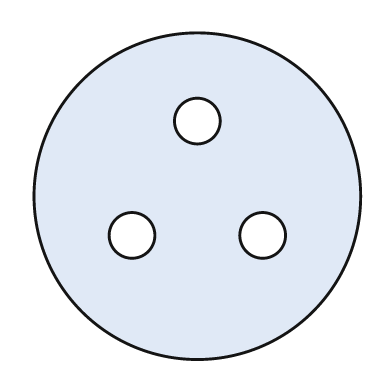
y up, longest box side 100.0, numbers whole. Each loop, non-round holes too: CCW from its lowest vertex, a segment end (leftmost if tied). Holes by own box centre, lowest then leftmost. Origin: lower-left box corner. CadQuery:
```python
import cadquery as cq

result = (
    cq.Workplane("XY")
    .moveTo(50.0, 50.0)
    .circle(50.0)
    .moveTo(30.0, 38.0)
    .circle(7.0)
    .moveTo(70.0, 38.0)
    .circle(7.0)
    .moveTo(50.0, 73.0)
    .circle(7.0)
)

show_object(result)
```